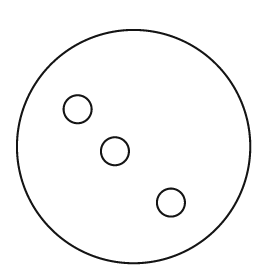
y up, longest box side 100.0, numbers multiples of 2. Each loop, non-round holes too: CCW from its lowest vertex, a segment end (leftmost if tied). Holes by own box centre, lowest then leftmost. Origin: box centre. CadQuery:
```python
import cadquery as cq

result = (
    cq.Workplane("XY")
    .moveTo(0.0, 0.0)
    .circle(50.0)
    .moveTo(16.0, -24.0)
    .circle(6.0)
    .moveTo(-8.0, -2.0)
    .circle(6.0)
    .moveTo(-24.0, 16.0)
    .circle(6.0)
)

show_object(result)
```